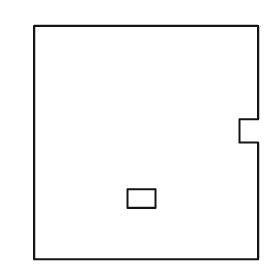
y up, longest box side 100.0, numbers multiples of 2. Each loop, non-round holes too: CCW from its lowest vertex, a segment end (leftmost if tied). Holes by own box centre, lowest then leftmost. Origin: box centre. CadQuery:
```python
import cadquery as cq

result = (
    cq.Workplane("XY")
    .moveTo(-48.0, -50.0)
    .lineTo(48.0, -50.0)
    .lineTo(48.0, 0.0)
    .lineTo(40.0, 0.0)
    .lineTo(40.0, 10.0)
    .lineTo(48.0, 10.0)
    .lineTo(48.0, 50.0)
    .lineTo(-48.0, 50.0)
    .close()
    .moveTo(-8.0, -28.0)
    .lineTo(4.0, -28.0)
    .lineTo(4.0, -20.0)
    .lineTo(-8.0, -20.0)
    .close()
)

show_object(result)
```